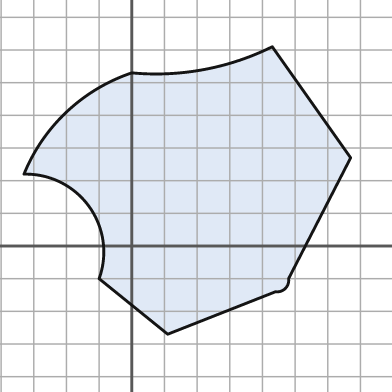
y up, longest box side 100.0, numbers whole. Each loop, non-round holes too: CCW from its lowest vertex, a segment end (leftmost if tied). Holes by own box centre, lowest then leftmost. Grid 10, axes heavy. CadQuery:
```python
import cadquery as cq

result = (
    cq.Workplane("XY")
    .moveTo(11.0, -27.0)
    .lineTo(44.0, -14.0)
    .threePointArc((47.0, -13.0), (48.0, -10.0))
    .lineTo(67.0, 27.0)
    .lineTo(43.0, 61.0)
    .threePointArc((22.0, 54.0), (0.0, 53.0))
    .threePointArc((-20.0, 41.0), (-33.0, 22.0))
    .threePointArc((-13.0, 12.0), (-10.0, -10.0))
    .close()
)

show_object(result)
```